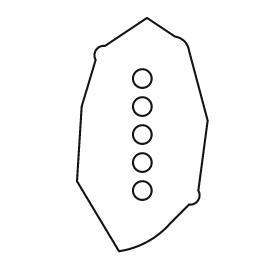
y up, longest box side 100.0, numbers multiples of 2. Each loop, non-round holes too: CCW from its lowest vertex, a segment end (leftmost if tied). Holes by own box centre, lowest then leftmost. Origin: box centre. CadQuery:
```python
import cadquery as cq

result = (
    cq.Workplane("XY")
    .moveTo(-10.0, -50.0)
    .threePointArc((2.0, -46.0), (12.0, -38.0))
    .lineTo(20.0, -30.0)
    .threePointArc((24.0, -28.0), (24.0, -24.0))
    .lineTo(28.0, 6.0)
    .lineTo(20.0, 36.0)
    .threePointArc((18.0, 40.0), (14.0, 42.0))
    .lineTo(2.0, 50.0)
    .lineTo(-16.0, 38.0)
    .threePointArc((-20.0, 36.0), (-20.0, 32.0))
    .lineTo(-26.0, 12.0)
    .lineTo(-28.0, -20.0)
    .close()
    .moveTo(0.0, -24.0)
    .circle(4.0)
    .moveTo(0.0, -12.0)
    .circle(4.0)
    .moveTo(0.0, 0.0)
    .circle(4.0)
    .moveTo(0.0, 12.0)
    .circle(4.0)
    .moveTo(0.0, 24.0)
    .circle(4.0)
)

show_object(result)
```